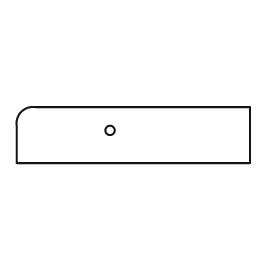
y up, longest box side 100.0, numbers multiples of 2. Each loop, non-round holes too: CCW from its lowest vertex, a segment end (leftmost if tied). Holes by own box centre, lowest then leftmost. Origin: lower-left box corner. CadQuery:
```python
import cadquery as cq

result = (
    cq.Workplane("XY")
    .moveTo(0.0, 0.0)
    .lineTo(100.0, 0.0)
    .lineTo(100.0, 24.0)
    .lineTo(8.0, 24.0)
    .threePointArc((2.0, 22.0), (0.0, 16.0))
    .close()
    .moveTo(40.0, 14.0)
    .circle(2.0)
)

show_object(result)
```